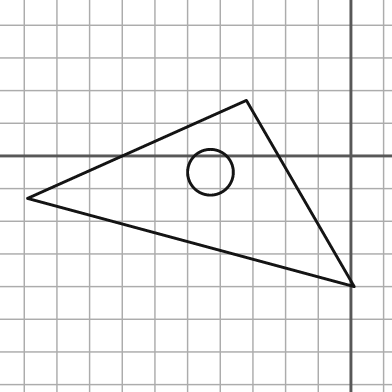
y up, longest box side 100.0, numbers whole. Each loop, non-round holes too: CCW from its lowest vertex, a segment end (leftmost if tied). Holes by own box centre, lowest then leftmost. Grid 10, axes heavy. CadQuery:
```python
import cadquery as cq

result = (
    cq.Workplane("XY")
    .moveTo(1.0, -40.0)
    .lineTo(-32.0, 17.0)
    .lineTo(-99.0, -13.0)
    .close()
    .moveTo(-43.0, -5.0)
    .circle(7.0)
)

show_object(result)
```